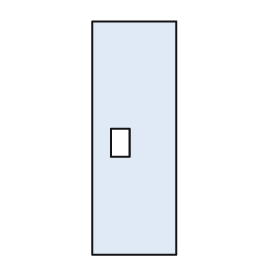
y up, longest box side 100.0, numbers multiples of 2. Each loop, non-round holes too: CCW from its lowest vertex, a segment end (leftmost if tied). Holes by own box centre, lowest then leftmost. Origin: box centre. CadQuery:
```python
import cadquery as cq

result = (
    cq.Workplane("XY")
    .moveTo(-18.0, -50.0)
    .lineTo(18.0, -50.0)
    .lineTo(18.0, 50.0)
    .lineTo(-18.0, 50.0)
    .close()
    .moveTo(-10.0, -8.0)
    .lineTo(-2.0, -8.0)
    .lineTo(-2.0, 4.0)
    .lineTo(-10.0, 4.0)
    .close()
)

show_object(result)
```